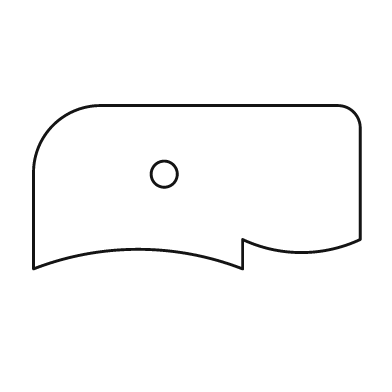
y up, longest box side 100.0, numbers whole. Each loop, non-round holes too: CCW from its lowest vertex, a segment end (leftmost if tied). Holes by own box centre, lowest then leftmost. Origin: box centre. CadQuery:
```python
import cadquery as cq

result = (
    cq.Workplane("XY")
    .moveTo(-50.0, -25.0)
    .threePointArc((-18.0, -19.0), (14.0, -25.0))
    .lineTo(14.0, -16.0)
    .threePointArc((32.0, -20.0), (50.0, -16.0))
    .lineTo(50.0, 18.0)
    .threePointArc((48.0, 23.0), (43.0, 25.0))
    .lineTo(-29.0, 25.0)
    .threePointArc((-44.0, 19.0), (-50.0, 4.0))
    .close()
    .moveTo(-10.0, 4.0)
    .circle(4.0)
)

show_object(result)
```